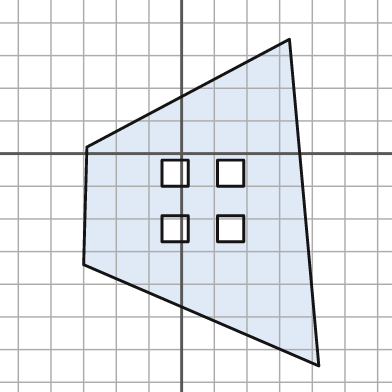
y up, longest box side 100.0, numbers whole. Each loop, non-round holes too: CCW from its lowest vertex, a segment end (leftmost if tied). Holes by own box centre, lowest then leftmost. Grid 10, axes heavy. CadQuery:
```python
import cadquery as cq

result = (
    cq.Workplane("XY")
    .moveTo(42.0, -65.0)
    .lineTo(33.0, 35.0)
    .lineTo(-29.0, 2.0)
    .lineTo(-30.0, -34.0)
    .close()
    .moveTo(-6.0, -27.0)
    .lineTo(2.0, -27.0)
    .lineTo(2.0, -19.0)
    .lineTo(-6.0, -19.0)
    .close()
    .moveTo(11.0, -27.0)
    .lineTo(19.0, -27.0)
    .lineTo(19.0, -19.0)
    .lineTo(11.0, -19.0)
    .close()
    .moveTo(-6.0, -10.0)
    .lineTo(2.0, -10.0)
    .lineTo(2.0, -2.0)
    .lineTo(-6.0, -2.0)
    .close()
    .moveTo(11.0, -10.0)
    .lineTo(19.0, -10.0)
    .lineTo(19.0, -2.0)
    .lineTo(11.0, -2.0)
    .close()
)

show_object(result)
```